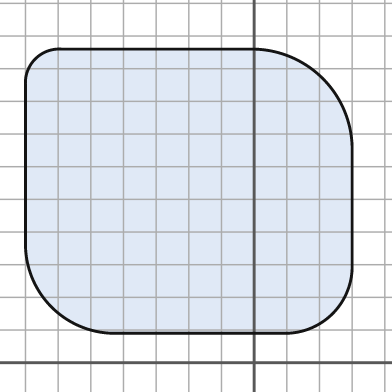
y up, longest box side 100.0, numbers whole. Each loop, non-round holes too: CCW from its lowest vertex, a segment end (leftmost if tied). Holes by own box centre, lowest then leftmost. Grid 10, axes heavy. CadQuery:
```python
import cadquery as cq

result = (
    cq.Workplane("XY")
    .moveTo(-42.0, 9.0)
    .lineTo(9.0, 9.0)
    .threePointArc((24.0, 15.0), (30.0, 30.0))
    .lineTo(30.0, 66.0)
    .threePointArc((21.0, 87.0), (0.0, 96.0))
    .lineTo(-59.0, 96.0)
    .threePointArc((-67.0, 93.0), (-70.0, 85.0))
    .lineTo(-70.0, 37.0)
    .threePointArc((-62.0, 17.0), (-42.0, 9.0))
    .close()
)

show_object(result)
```